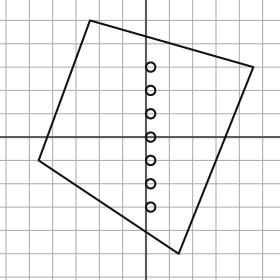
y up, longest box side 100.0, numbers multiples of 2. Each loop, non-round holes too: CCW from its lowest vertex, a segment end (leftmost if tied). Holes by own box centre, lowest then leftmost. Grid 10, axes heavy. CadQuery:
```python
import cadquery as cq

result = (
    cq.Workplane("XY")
    .moveTo(14.0, -50.0)
    .lineTo(46.0, 30.0)
    .lineTo(-24.0, 50.0)
    .lineTo(-46.0, -10.0)
    .close()
    .moveTo(2.0, -30.0)
    .circle(2.0)
    .moveTo(2.0, -20.0)
    .circle(2.0)
    .moveTo(2.0, -10.0)
    .circle(2.0)
    .moveTo(2.0, 0.0)
    .circle(2.0)
    .moveTo(2.0, 10.0)
    .circle(2.0)
    .moveTo(2.0, 20.0)
    .circle(2.0)
    .moveTo(2.0, 30.0)
    .circle(2.0)
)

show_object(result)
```